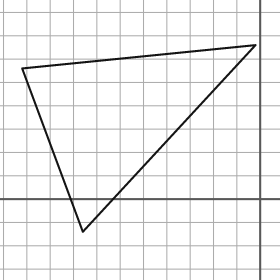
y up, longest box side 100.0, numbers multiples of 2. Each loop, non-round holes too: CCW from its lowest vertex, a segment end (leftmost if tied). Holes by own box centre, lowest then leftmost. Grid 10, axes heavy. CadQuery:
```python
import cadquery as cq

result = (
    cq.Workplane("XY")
    .moveTo(-76.0, -14.0)
    .lineTo(-2.0, 66.0)
    .lineTo(-102.0, 56.0)
    .close()
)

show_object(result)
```